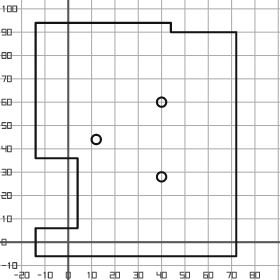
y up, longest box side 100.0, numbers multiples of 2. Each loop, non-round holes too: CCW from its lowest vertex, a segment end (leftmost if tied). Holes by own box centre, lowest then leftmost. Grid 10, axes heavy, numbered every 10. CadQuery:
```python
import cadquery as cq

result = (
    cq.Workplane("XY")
    .moveTo(-14.0, -6.0)
    .lineTo(72.0, -6.0)
    .lineTo(72.0, 90.0)
    .lineTo(44.0, 90.0)
    .lineTo(44.0, 94.0)
    .lineTo(-14.0, 94.0)
    .lineTo(-14.0, 36.0)
    .lineTo(4.0, 36.0)
    .lineTo(4.0, 6.0)
    .lineTo(-14.0, 6.0)
    .close()
    .moveTo(40.0, 28.0)
    .circle(2.0)
    .moveTo(12.0, 44.0)
    .circle(2.0)
    .moveTo(40.0, 60.0)
    .circle(2.0)
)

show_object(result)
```